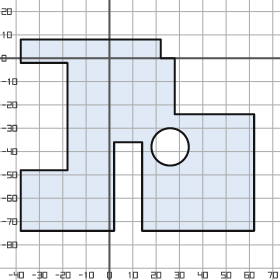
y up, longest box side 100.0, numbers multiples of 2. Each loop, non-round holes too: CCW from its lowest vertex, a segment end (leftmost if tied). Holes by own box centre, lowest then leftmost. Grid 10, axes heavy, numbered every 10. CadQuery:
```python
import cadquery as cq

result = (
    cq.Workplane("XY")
    .moveTo(-38.0, -74.0)
    .lineTo(2.0, -74.0)
    .lineTo(2.0, -36.0)
    .lineTo(14.0, -36.0)
    .lineTo(14.0, -74.0)
    .lineTo(62.0, -74.0)
    .lineTo(62.0, -24.0)
    .lineTo(28.0, -24.0)
    .lineTo(28.0, 0.0)
    .lineTo(22.0, 0.0)
    .lineTo(22.0, 8.0)
    .lineTo(-38.0, 8.0)
    .lineTo(-38.0, -2.0)
    .lineTo(-18.0, -2.0)
    .lineTo(-18.0, -48.0)
    .lineTo(-38.0, -48.0)
    .close()
    .moveTo(26.0, -38.0)
    .circle(8.0)
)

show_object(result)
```